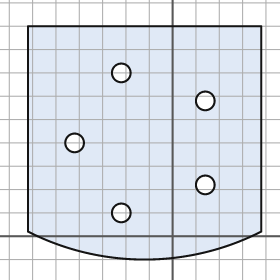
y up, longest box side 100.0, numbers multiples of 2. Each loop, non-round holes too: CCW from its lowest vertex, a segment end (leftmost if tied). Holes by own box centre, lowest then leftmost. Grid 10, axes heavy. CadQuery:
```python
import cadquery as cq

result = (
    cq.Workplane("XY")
    .moveTo(-62.0, 2.0)
    .threePointArc((-12.0, -10.0), (38.0, 2.0))
    .lineTo(38.0, 90.0)
    .lineTo(-62.0, 90.0)
    .close()
    .moveTo(-22.0, 10.0)
    .circle(4.0)
    .moveTo(14.0, 22.0)
    .circle(4.0)
    .moveTo(-42.0, 40.0)
    .circle(4.0)
    .moveTo(14.0, 58.0)
    .circle(4.0)
    .moveTo(-22.0, 70.0)
    .circle(4.0)
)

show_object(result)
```